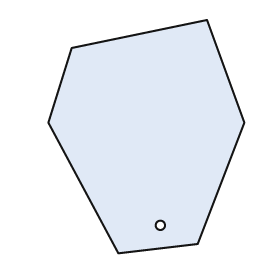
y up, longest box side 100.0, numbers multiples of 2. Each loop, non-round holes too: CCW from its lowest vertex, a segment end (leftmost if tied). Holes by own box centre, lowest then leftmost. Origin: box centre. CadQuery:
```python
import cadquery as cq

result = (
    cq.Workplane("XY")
    .moveTo(-12.0, -50.0)
    .lineTo(22.0, -46.0)
    .lineTo(42.0, 6.0)
    .lineTo(26.0, 50.0)
    .lineTo(-32.0, 38.0)
    .lineTo(-42.0, 6.0)
    .close()
    .moveTo(6.0, -38.0)
    .circle(2.0)
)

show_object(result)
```